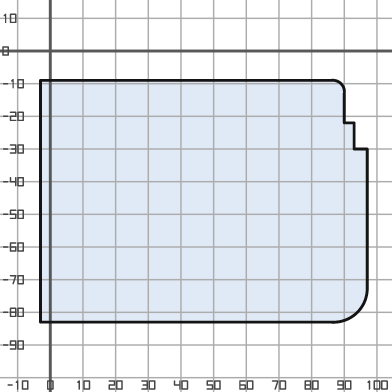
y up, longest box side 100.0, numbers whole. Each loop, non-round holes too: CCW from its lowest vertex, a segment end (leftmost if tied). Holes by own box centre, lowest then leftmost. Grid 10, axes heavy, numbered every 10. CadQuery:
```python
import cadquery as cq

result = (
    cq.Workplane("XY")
    .moveTo(-3.0, -83.0)
    .lineTo(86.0, -83.0)
    .threePointArc((94.0, -80.0), (97.0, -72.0))
    .lineTo(97.0, -30.0)
    .lineTo(93.0, -30.0)
    .lineTo(93.0, -22.0)
    .lineTo(90.0, -22.0)
    .lineTo(90.0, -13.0)
    .threePointArc((89.0, -10.0), (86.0, -9.0))
    .lineTo(-3.0, -9.0)
    .close()
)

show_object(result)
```